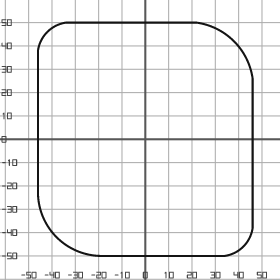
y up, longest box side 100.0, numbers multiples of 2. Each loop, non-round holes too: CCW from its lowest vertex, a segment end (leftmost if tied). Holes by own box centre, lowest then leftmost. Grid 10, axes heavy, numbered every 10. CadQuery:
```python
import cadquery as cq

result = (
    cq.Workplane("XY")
    .moveTo(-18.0, -50.0)
    .lineTo(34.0, -50.0)
    .threePointArc((42.0, -46.0), (46.0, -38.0))
    .lineTo(46.0, 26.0)
    .threePointArc((38.0, 42.0), (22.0, 50.0))
    .lineTo(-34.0, 50.0)
    .threePointArc((-42.0, 46.0), (-46.0, 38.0))
    .lineTo(-46.0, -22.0)
    .threePointArc((-38.0, -42.0), (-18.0, -50.0))
    .close()
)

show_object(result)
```